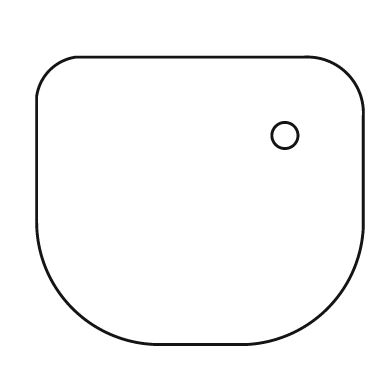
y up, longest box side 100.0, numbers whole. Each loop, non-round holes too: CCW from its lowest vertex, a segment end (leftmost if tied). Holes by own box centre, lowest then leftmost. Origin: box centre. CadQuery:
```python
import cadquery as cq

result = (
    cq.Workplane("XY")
    .moveTo(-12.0, -44.0)
    .lineTo(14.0, -44.0)
    .threePointArc((39.0, -33.0), (50.0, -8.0))
    .lineTo(50.0, 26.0)
    .threePointArc((45.0, 39.0), (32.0, 44.0))
    .lineTo(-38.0, 44.0)
    .threePointArc((-46.0, 40.0), (-50.0, 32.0))
    .lineTo(-50.0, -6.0)
    .threePointArc((-39.0, -33.0), (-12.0, -44.0))
    .close()
    .moveTo(26.0, 20.0)
    .circle(4.0)
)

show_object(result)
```